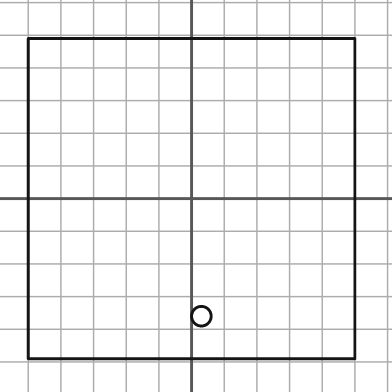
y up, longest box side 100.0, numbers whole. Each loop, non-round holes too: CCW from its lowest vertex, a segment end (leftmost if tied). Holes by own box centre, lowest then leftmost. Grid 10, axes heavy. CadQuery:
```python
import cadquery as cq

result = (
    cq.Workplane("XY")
    .moveTo(-50.0, -49.0)
    .lineTo(50.0, -49.0)
    .lineTo(50.0, 49.0)
    .lineTo(-50.0, 49.0)
    .close()
    .moveTo(3.0, -36.0)
    .circle(3.0)
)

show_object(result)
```